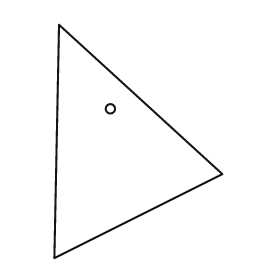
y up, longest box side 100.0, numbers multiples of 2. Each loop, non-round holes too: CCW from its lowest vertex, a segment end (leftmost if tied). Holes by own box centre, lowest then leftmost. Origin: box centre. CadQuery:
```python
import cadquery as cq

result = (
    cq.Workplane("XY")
    .moveTo(-36.0, -50.0)
    .lineTo(36.0, -14.0)
    .lineTo(-34.0, 50.0)
    .close()
    .moveTo(-12.0, 14.0)
    .circle(2.0)
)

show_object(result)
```